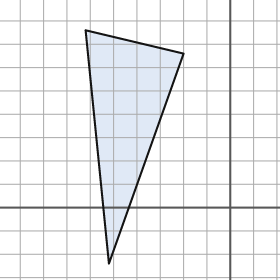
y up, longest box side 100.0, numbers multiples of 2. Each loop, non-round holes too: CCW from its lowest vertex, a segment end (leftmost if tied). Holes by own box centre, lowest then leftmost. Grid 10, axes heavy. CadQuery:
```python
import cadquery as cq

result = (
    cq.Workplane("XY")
    .moveTo(-52.0, -24.0)
    .lineTo(-20.0, 66.0)
    .lineTo(-62.0, 76.0)
    .close()
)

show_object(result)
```